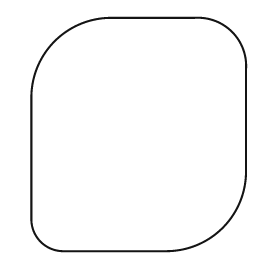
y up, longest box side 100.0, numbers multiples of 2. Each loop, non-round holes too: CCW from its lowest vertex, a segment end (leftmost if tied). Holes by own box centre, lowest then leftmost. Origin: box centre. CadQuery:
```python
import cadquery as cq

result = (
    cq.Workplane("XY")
    .moveTo(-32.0, -50.0)
    .lineTo(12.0, -50.0)
    .threePointArc((36.0, -40.0), (46.0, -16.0))
    .lineTo(46.0, 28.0)
    .threePointArc((40.0, 44.0), (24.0, 50.0))
    .lineTo(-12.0, 50.0)
    .threePointArc((-36.0, 40.0), (-46.0, 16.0))
    .lineTo(-46.0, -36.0)
    .threePointArc((-42.0, -46.0), (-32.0, -50.0))
    .close()
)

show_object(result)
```